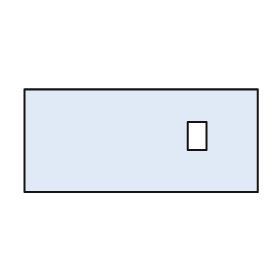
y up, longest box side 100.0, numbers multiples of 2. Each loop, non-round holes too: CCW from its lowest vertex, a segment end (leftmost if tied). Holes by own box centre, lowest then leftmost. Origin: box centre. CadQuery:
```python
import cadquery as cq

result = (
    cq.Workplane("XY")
    .moveTo(-50.0, -22.0)
    .lineTo(50.0, -22.0)
    .lineTo(50.0, 22.0)
    .lineTo(-50.0, 22.0)
    .close()
    .moveTo(20.0, -4.0)
    .lineTo(28.0, -4.0)
    .lineTo(28.0, 8.0)
    .lineTo(20.0, 8.0)
    .close()
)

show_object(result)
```